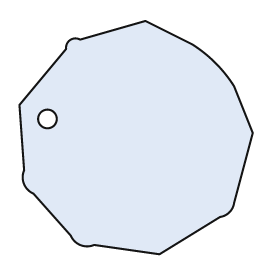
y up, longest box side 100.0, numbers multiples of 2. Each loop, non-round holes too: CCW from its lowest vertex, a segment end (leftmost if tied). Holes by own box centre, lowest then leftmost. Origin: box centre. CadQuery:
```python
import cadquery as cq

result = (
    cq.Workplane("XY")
    .moveTo(10.0, -50.0)
    .lineTo(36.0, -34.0)
    .threePointArc((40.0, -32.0), (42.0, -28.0))
    .lineTo(50.0, 2.0)
    .lineTo(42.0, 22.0)
    .threePointArc((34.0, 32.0), (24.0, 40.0))
    .lineTo(4.0, 50.0)
    .lineTo(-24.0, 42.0)
    .threePointArc((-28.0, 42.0), (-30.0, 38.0))
    .lineTo(-50.0, 14.0)
    .lineTo(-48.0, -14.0)
    .threePointArc((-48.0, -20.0), (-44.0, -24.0))
    .lineTo(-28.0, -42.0)
    .threePointArc((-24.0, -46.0), (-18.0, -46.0))
    .close()
    .moveTo(-38.0, 8.0)
    .circle(4.0)
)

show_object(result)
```